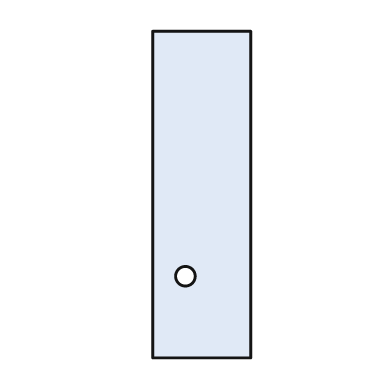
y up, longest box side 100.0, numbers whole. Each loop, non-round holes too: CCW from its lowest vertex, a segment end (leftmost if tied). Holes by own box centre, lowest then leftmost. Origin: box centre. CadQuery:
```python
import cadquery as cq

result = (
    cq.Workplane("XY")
    .moveTo(-15.0, -50.0)
    .lineTo(15.0, -50.0)
    .lineTo(15.0, 50.0)
    .lineTo(-15.0, 50.0)
    .close()
    .moveTo(-5.0, -25.0)
    .circle(3.0)
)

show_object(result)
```